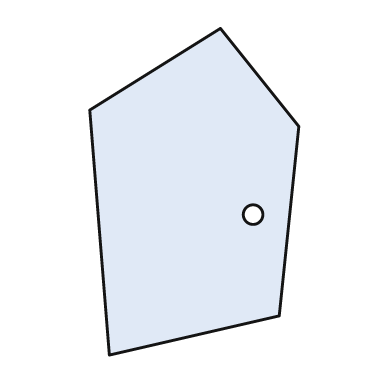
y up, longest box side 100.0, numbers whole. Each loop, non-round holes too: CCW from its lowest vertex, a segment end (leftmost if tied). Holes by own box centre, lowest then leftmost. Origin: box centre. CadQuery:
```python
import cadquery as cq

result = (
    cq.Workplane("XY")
    .moveTo(-26.0, -50.0)
    .lineTo(26.0, -38.0)
    .lineTo(32.0, 20.0)
    .lineTo(8.0, 50.0)
    .lineTo(-32.0, 25.0)
    .close()
    .moveTo(18.0, -7.0)
    .circle(3.0)
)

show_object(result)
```